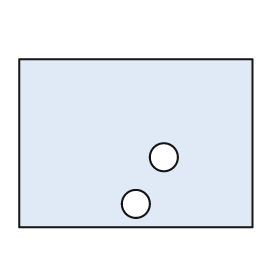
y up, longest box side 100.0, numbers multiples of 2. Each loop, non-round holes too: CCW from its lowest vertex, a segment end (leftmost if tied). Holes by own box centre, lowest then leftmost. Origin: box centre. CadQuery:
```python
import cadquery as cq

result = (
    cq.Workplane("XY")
    .moveTo(-50.0, -36.0)
    .lineTo(50.0, -36.0)
    .lineTo(50.0, 36.0)
    .lineTo(-50.0, 36.0)
    .close()
    .moveTo(0.0, -26.0)
    .circle(6.0)
    .moveTo(12.0, -6.0)
    .circle(6.0)
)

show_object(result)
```